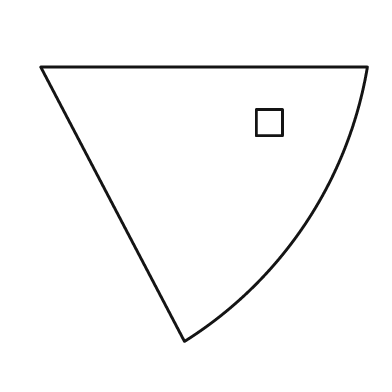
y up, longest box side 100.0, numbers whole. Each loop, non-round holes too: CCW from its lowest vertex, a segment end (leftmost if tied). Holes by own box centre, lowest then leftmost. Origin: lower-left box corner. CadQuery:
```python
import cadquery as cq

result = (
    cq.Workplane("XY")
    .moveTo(44.0, 0.0)
    .threePointArc((81.0, 36.0), (100.0, 84.0))
    .lineTo(0.0, 84.0)
    .close()
    .moveTo(66.0, 63.0)
    .lineTo(74.0, 63.0)
    .lineTo(74.0, 71.0)
    .lineTo(66.0, 71.0)
    .close()
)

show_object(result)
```